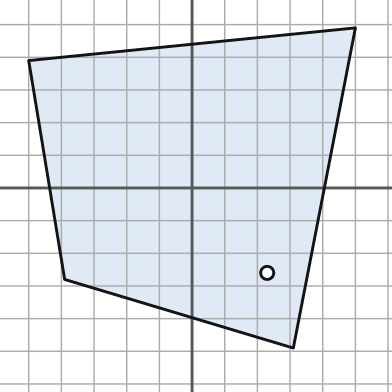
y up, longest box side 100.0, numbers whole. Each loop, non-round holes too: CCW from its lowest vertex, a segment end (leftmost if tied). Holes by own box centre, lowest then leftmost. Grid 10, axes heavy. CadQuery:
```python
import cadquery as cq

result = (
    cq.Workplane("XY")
    .moveTo(31.0, -49.0)
    .lineTo(50.0, 49.0)
    .lineTo(-50.0, 39.0)
    .lineTo(-39.0, -28.0)
    .close()
    .moveTo(23.0, -26.0)
    .circle(2.0)
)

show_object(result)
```